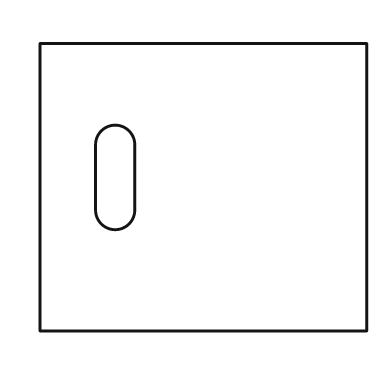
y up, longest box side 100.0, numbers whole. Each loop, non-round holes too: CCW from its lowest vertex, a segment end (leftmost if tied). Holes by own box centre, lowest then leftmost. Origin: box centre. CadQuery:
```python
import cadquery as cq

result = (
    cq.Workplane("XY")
    .moveTo(-50.0, -44.0)
    .lineTo(50.0, -44.0)
    .lineTo(50.0, 44.0)
    .lineTo(-50.0, 44.0)
    .close()
    .moveTo(-33.0, -7.0)
    .threePointArc((-27.0, -13.0), (-21.0, -7.0))
    .lineTo(-21.0, 13.0)
    .threePointArc((-27.0, 19.0), (-33.0, 13.0))
    .close()
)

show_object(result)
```